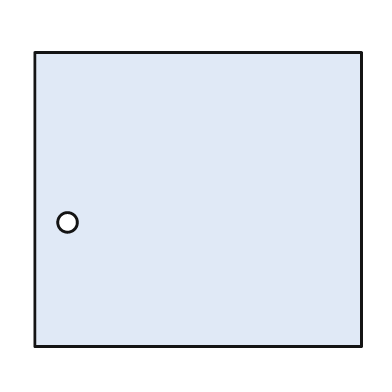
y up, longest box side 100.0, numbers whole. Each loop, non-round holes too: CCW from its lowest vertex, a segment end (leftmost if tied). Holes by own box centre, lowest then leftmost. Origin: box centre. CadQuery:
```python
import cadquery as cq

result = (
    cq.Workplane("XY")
    .moveTo(-50.0, -45.0)
    .lineTo(50.0, -45.0)
    .lineTo(50.0, 45.0)
    .lineTo(-50.0, 45.0)
    .close()
    .moveTo(-40.0, -7.0)
    .circle(3.0)
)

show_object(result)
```